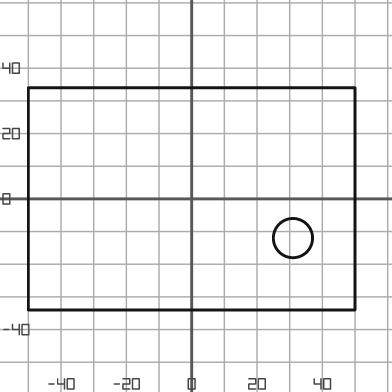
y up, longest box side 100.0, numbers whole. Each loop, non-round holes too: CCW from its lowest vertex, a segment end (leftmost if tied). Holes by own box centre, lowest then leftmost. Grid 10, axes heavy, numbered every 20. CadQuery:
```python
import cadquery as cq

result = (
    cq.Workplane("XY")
    .moveTo(-50.0, -34.0)
    .lineTo(50.0, -34.0)
    .lineTo(50.0, 34.0)
    .lineTo(-50.0, 34.0)
    .close()
    .moveTo(31.0, -12.0)
    .circle(6.0)
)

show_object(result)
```